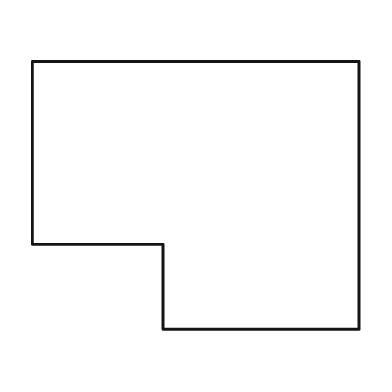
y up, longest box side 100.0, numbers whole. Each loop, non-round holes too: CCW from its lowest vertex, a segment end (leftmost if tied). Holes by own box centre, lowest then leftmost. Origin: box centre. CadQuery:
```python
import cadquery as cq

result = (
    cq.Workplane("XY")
    .moveTo(-10.0, -41.0)
    .lineTo(50.0, -41.0)
    .lineTo(50.0, 41.0)
    .lineTo(-50.0, 41.0)
    .lineTo(-50.0, -15.0)
    .lineTo(-10.0, -15.0)
    .close()
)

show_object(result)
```